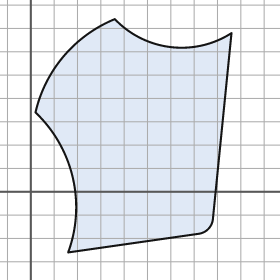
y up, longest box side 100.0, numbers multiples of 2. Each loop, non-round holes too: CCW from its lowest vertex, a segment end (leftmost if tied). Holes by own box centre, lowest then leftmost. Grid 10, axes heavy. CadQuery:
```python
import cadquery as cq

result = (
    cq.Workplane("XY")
    .moveTo(16.0, -26.0)
    .lineTo(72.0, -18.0)
    .threePointArc((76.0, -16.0), (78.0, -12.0))
    .lineTo(86.0, 68.0)
    .threePointArc((60.0, 62.0), (36.0, 74.0))
    .threePointArc((14.0, 58.0), (2.0, 34.0))
    .threePointArc((18.0, 6.0), (16.0, -26.0))
    .close()
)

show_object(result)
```